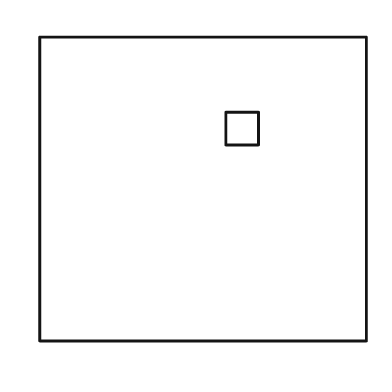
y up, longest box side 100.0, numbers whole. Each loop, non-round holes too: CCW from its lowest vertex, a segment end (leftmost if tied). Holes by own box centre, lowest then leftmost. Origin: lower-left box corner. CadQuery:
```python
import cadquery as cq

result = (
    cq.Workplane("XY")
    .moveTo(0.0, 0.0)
    .lineTo(100.0, 0.0)
    .lineTo(100.0, 93.0)
    .lineTo(0.0, 93.0)
    .close()
    .moveTo(57.0, 60.0)
    .lineTo(67.0, 60.0)
    .lineTo(67.0, 70.0)
    .lineTo(57.0, 70.0)
    .close()
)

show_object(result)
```